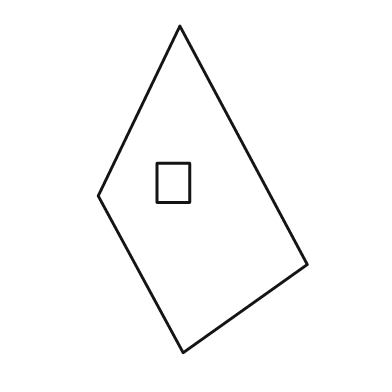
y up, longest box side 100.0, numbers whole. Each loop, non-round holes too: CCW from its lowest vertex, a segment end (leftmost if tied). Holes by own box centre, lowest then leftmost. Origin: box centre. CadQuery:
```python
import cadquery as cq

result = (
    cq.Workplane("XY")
    .moveTo(-6.0, -50.0)
    .lineTo(32.0, -23.0)
    .lineTo(-7.0, 50.0)
    .lineTo(-32.0, -2.0)
    .close()
    .moveTo(-14.0, -4.0)
    .lineTo(-4.0, -4.0)
    .lineTo(-4.0, 8.0)
    .lineTo(-14.0, 8.0)
    .close()
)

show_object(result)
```